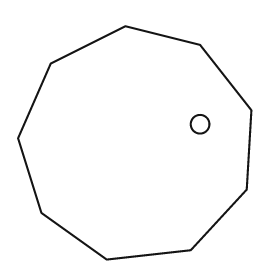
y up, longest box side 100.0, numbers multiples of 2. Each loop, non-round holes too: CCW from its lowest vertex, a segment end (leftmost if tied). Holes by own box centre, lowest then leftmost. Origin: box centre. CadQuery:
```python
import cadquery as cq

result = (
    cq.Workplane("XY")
    .moveTo(-12.0, -50.0)
    .lineTo(24.0, -46.0)
    .lineTo(48.0, -20.0)
    .lineTo(50.0, 14.0)
    .lineTo(28.0, 42.0)
    .lineTo(-4.0, 50.0)
    .lineTo(-36.0, 34.0)
    .lineTo(-50.0, 2.0)
    .lineTo(-40.0, -30.0)
    .close()
    .moveTo(28.0, 8.0)
    .circle(4.0)
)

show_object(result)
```